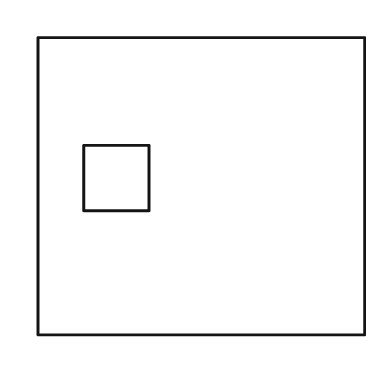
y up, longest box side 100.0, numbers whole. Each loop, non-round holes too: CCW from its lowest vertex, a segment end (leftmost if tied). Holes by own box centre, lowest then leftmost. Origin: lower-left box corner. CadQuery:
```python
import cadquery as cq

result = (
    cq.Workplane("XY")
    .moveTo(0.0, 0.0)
    .lineTo(100.0, 0.0)
    .lineTo(100.0, 91.0)
    .lineTo(0.0, 91.0)
    .close()
    .moveTo(14.0, 38.0)
    .lineTo(34.0, 38.0)
    .lineTo(34.0, 58.0)
    .lineTo(14.0, 58.0)
    .close()
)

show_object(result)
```